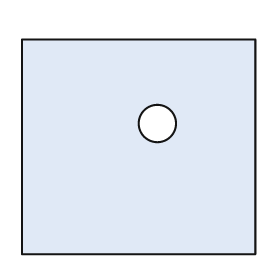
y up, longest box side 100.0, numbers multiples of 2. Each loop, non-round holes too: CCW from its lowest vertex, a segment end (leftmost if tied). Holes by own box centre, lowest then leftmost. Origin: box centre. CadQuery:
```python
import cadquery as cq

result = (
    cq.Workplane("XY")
    .moveTo(-50.0, -46.0)
    .lineTo(50.0, -46.0)
    .lineTo(50.0, 46.0)
    .lineTo(-50.0, 46.0)
    .close()
    .moveTo(8.0, 10.0)
    .circle(8.0)
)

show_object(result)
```